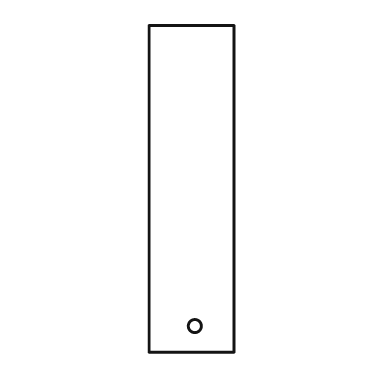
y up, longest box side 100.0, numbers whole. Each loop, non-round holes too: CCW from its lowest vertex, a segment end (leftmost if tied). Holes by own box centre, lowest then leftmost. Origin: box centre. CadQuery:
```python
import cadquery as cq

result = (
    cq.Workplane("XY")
    .moveTo(-13.0, -50.0)
    .lineTo(13.0, -50.0)
    .lineTo(13.0, 50.0)
    .lineTo(-13.0, 50.0)
    .close()
    .moveTo(1.0, -42.0)
    .circle(2.0)
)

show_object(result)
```